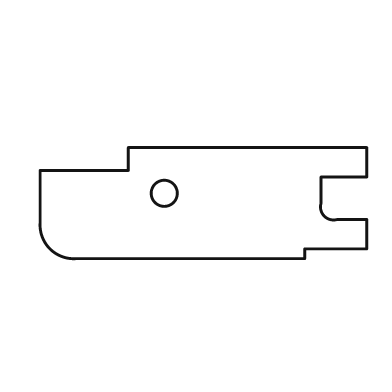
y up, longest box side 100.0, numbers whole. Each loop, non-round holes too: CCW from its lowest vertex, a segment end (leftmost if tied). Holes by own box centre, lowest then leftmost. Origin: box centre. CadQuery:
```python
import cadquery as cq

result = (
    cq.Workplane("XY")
    .moveTo(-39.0, -17.0)
    .lineTo(31.0, -17.0)
    .lineTo(31.0, -14.0)
    .lineTo(50.0, -14.0)
    .lineTo(50.0, -5.0)
    .lineTo(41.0, -5.0)
    .threePointArc((37.0, -4.0), (36.0, 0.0))
    .lineTo(36.0, 8.0)
    .lineTo(50.0, 8.0)
    .lineTo(50.0, 17.0)
    .lineTo(-23.0, 17.0)
    .lineTo(-23.0, 10.0)
    .lineTo(-50.0, 10.0)
    .lineTo(-50.0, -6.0)
    .threePointArc((-47.0, -14.0), (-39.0, -17.0))
    .close()
    .moveTo(-12.0, 3.0)
    .circle(4.0)
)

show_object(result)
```